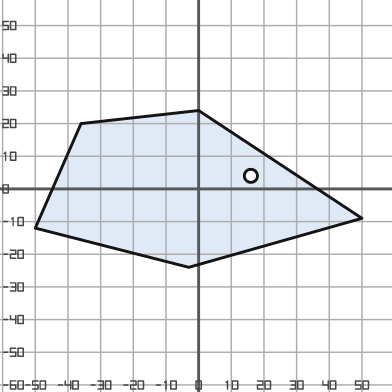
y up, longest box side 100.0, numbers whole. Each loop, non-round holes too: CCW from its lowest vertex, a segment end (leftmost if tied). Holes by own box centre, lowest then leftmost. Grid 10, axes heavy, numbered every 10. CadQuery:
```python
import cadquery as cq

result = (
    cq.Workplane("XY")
    .moveTo(-3.0, -24.0)
    .lineTo(50.0, -9.0)
    .lineTo(0.0, 24.0)
    .lineTo(-36.0, 20.0)
    .lineTo(-50.0, -12.0)
    .close()
    .moveTo(16.0, 4.0)
    .circle(2.0)
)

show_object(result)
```